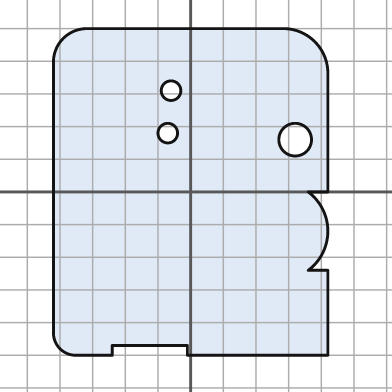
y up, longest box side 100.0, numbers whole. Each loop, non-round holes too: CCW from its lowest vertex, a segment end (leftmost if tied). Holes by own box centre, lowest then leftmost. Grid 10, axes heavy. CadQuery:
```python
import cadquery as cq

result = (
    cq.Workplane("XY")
    .moveTo(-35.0, -50.0)
    .lineTo(-24.0, -50.0)
    .lineTo(-24.0, -47.0)
    .lineTo(-1.0, -47.0)
    .lineTo(-1.0, -50.0)
    .lineTo(42.0, -50.0)
    .lineTo(42.0, -24.0)
    .lineTo(36.0, -24.0)
    .threePointArc((42.0, -12.0), (36.0, 0.0))
    .lineTo(42.0, 0.0)
    .lineTo(42.0, 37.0)
    .threePointArc((38.0, 46.0), (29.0, 50.0))
    .lineTo(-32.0, 50.0)
    .threePointArc((-39.0, 47.0), (-42.0, 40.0))
    .lineTo(-42.0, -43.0)
    .threePointArc((-40.0, -48.0), (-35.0, -50.0))
    .close()
    .moveTo(32.0, 16.0)
    .circle(5.0)
    .moveTo(-7.0, 18.0)
    .circle(3.0)
    .moveTo(-6.0, 31.0)
    .circle(3.0)
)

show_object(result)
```